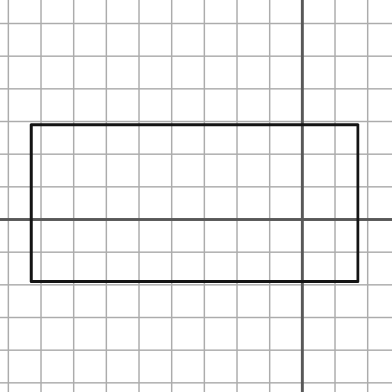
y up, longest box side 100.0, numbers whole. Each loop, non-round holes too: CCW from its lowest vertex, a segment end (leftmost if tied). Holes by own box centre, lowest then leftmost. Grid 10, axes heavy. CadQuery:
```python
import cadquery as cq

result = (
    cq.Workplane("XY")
    .moveTo(-83.0, -19.0)
    .lineTo(17.0, -19.0)
    .lineTo(17.0, 29.0)
    .lineTo(-83.0, 29.0)
    .close()
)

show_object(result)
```